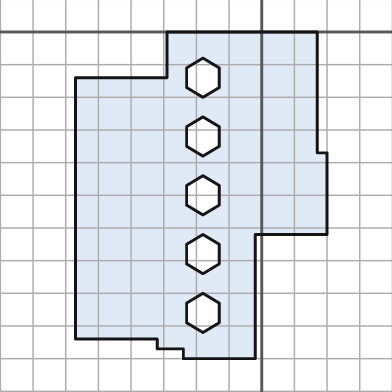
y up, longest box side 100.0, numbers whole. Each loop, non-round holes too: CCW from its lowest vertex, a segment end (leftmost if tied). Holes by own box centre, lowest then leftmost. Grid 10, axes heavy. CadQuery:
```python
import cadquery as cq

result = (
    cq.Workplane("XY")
    .moveTo(-24.0, -100.0)
    .lineTo(-2.0, -100.0)
    .lineTo(-2.0, -62.0)
    .lineTo(20.0, -62.0)
    .lineTo(20.0, -37.0)
    .lineTo(17.0, -37.0)
    .lineTo(17.0, 0.0)
    .lineTo(-29.0, 0.0)
    .lineTo(-29.0, -14.0)
    .lineTo(-57.0, -14.0)
    .lineTo(-57.0, -94.0)
    .lineTo(-32.0, -94.0)
    .lineTo(-32.0, -97.0)
    .lineTo(-24.0, -97.0)
    .close()
    .moveTo(-18.0, -92.0)
    .lineTo(-13.0, -89.0)
    .lineTo(-13.0, -83.0)
    .lineTo(-18.0, -80.0)
    .lineTo(-23.0, -83.0)
    .lineTo(-23.0, -89.0)
    .close()
    .moveTo(-18.0, -74.0)
    .lineTo(-13.0, -71.0)
    .lineTo(-13.0, -65.0)
    .lineTo(-18.0, -62.0)
    .lineTo(-23.0, -65.0)
    .lineTo(-23.0, -71.0)
    .close()
    .moveTo(-18.0, -56.0)
    .lineTo(-13.0, -53.0)
    .lineTo(-13.0, -47.0)
    .lineTo(-18.0, -44.0)
    .lineTo(-23.0, -47.0)
    .lineTo(-23.0, -53.0)
    .close()
    .moveTo(-18.0, -38.0)
    .lineTo(-13.0, -35.0)
    .lineTo(-13.0, -29.0)
    .lineTo(-18.0, -26.0)
    .lineTo(-23.0, -29.0)
    .lineTo(-23.0, -35.0)
    .close()
    .moveTo(-18.0, -20.0)
    .lineTo(-13.0, -17.0)
    .lineTo(-13.0, -11.0)
    .lineTo(-18.0, -8.0)
    .lineTo(-23.0, -11.0)
    .lineTo(-23.0, -17.0)
    .close()
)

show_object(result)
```